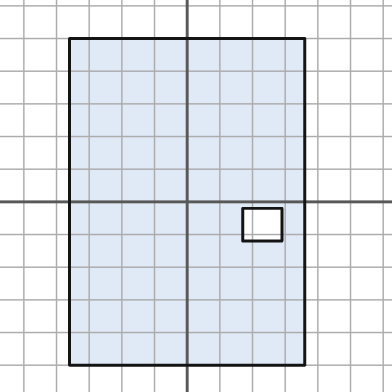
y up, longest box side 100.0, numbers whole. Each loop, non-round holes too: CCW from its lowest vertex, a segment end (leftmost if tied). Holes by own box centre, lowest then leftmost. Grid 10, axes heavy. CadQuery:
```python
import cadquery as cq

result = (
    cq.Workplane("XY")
    .moveTo(-36.0, -50.0)
    .lineTo(36.0, -50.0)
    .lineTo(36.0, 50.0)
    .lineTo(-36.0, 50.0)
    .close()
    .moveTo(17.0, -12.0)
    .lineTo(29.0, -12.0)
    .lineTo(29.0, -2.0)
    .lineTo(17.0, -2.0)
    .close()
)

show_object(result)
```